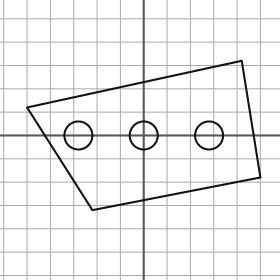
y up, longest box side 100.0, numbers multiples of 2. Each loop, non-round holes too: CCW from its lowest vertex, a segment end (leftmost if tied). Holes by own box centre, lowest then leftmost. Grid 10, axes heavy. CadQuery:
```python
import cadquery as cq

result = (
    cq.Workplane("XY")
    .moveTo(-22.0, -32.0)
    .lineTo(50.0, -18.0)
    .lineTo(42.0, 32.0)
    .lineTo(-50.0, 12.0)
    .close()
    .moveTo(-28.0, 0.0)
    .circle(6.0)
    .moveTo(0.0, 0.0)
    .circle(6.0)
    .moveTo(28.0, 0.0)
    .circle(6.0)
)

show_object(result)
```